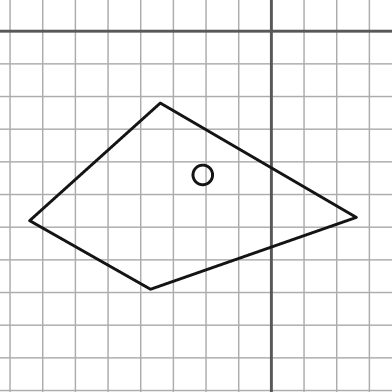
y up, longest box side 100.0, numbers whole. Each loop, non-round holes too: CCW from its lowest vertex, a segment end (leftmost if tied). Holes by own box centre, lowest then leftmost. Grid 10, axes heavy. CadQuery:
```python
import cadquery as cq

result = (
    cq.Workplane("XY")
    .moveTo(-37.0, -79.0)
    .lineTo(26.0, -57.0)
    .lineTo(-34.0, -22.0)
    .lineTo(-74.0, -58.0)
    .close()
    .moveTo(-21.0, -44.0)
    .circle(3.0)
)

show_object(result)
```